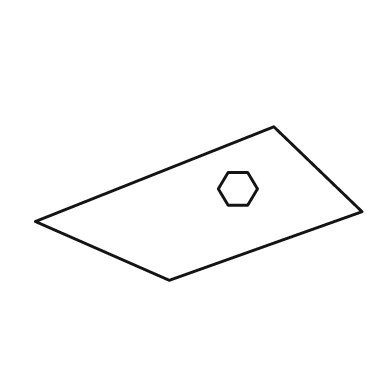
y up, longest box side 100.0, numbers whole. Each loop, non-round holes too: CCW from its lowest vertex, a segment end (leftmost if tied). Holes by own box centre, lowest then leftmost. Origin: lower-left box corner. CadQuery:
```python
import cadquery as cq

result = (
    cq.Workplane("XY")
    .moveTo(41.0, 0.0)
    .lineTo(100.0, 21.0)
    .lineTo(73.0, 47.0)
    .lineTo(0.0, 18.0)
    .close()
    .moveTo(59.0, 23.0)
    .lineTo(65.0, 23.0)
    .lineTo(68.0, 28.0)
    .lineTo(65.0, 33.0)
    .lineTo(59.0, 33.0)
    .lineTo(56.0, 28.0)
    .close()
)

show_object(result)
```